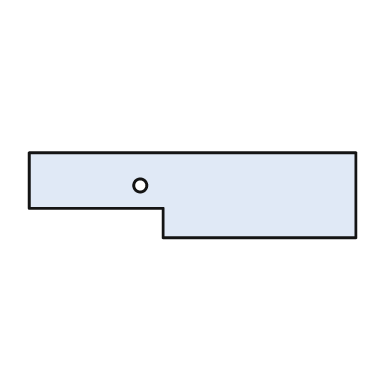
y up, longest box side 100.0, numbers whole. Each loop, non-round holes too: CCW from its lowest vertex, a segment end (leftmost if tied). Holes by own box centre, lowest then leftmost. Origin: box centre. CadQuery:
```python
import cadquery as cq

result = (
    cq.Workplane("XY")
    .moveTo(-9.0, -13.0)
    .lineTo(50.0, -13.0)
    .lineTo(50.0, 13.0)
    .lineTo(-50.0, 13.0)
    .lineTo(-50.0, -4.0)
    .lineTo(-9.0, -4.0)
    .close()
    .moveTo(-16.0, 3.0)
    .circle(2.0)
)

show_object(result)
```